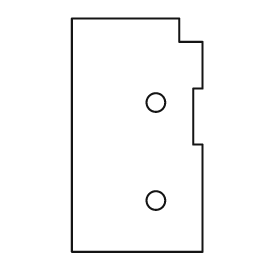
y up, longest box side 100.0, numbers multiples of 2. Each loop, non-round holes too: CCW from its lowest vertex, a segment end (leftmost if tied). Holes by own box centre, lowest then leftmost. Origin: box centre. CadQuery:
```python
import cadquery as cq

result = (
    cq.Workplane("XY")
    .moveTo(-28.0, -50.0)
    .lineTo(28.0, -50.0)
    .lineTo(28.0, -4.0)
    .lineTo(24.0, -4.0)
    .lineTo(24.0, 20.0)
    .lineTo(28.0, 20.0)
    .lineTo(28.0, 40.0)
    .lineTo(18.0, 40.0)
    .lineTo(18.0, 50.0)
    .lineTo(-28.0, 50.0)
    .close()
    .moveTo(8.0, -28.0)
    .circle(4.0)
    .moveTo(8.0, 14.0)
    .circle(4.0)
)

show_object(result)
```